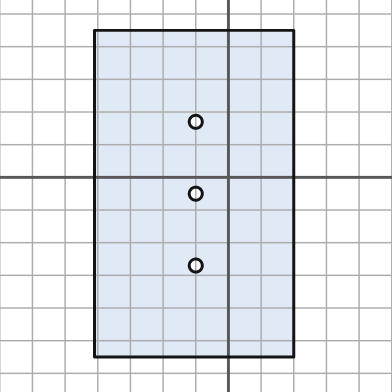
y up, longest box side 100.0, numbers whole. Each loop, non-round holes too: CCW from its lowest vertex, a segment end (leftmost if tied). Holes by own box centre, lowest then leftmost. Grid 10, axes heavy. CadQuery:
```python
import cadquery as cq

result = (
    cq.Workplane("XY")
    .moveTo(-41.0, -55.0)
    .lineTo(20.0, -55.0)
    .lineTo(20.0, 45.0)
    .lineTo(-41.0, 45.0)
    .close()
    .moveTo(-10.0, -27.0)
    .circle(2.0)
    .moveTo(-10.0, -5.0)
    .circle(2.0)
    .moveTo(-10.0, 17.0)
    .circle(2.0)
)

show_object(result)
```